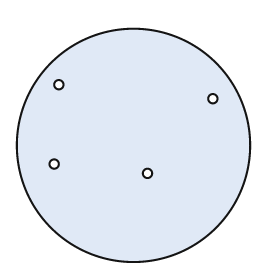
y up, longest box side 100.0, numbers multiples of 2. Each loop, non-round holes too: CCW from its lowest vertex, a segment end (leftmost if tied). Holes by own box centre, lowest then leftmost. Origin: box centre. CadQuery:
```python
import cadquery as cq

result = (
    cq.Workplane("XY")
    .moveTo(0.0, 0.0)
    .circle(50.0)
    .moveTo(6.0, -12.0)
    .circle(2.0)
    .moveTo(-34.0, -8.0)
    .circle(2.0)
    .moveTo(34.0, 20.0)
    .circle(2.0)
    .moveTo(-32.0, 26.0)
    .circle(2.0)
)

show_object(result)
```